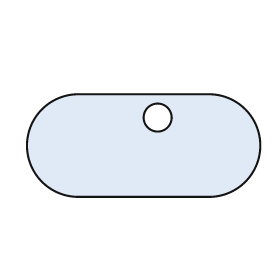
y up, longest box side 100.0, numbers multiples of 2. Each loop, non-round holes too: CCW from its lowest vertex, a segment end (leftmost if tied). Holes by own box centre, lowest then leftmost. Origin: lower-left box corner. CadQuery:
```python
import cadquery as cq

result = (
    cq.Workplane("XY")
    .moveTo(22.0, 0.0)
    .lineTo(78.0, 0.0)
    .threePointArc((100.0, 22.0), (78.0, 44.0))
    .lineTo(22.0, 44.0)
    .threePointArc((0.0, 22.0), (22.0, 0.0))
    .close()
    .moveTo(56.0, 34.0)
    .circle(6.0)
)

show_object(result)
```